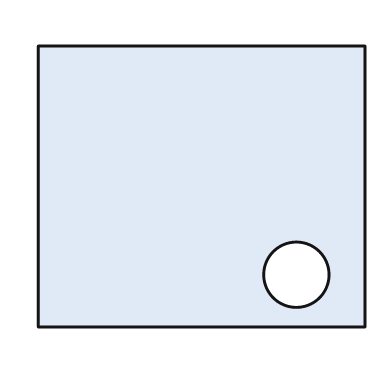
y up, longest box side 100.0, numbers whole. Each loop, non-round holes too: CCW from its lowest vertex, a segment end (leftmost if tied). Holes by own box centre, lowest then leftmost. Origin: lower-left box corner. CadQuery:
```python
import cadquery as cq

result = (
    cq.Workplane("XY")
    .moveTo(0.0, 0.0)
    .lineTo(100.0, 0.0)
    .lineTo(100.0, 86.0)
    .lineTo(0.0, 86.0)
    .close()
    .moveTo(79.0, 16.0)
    .circle(10.0)
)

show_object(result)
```